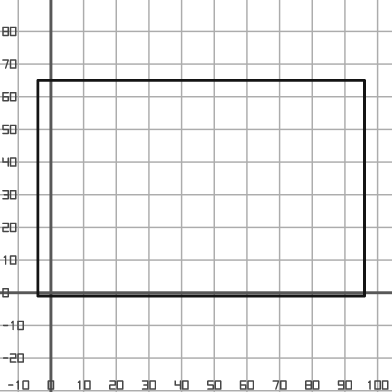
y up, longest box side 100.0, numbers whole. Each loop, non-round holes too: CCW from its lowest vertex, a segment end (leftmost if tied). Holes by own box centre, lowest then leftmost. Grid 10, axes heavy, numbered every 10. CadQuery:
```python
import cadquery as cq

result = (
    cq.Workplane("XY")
    .moveTo(-4.0, -1.0)
    .lineTo(96.0, -1.0)
    .lineTo(96.0, 65.0)
    .lineTo(-4.0, 65.0)
    .close()
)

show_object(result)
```